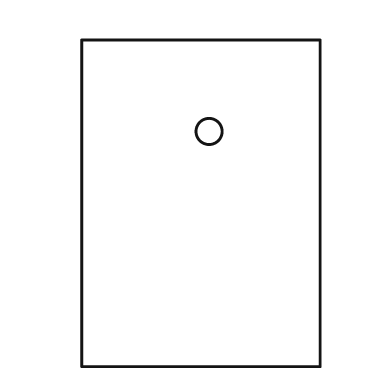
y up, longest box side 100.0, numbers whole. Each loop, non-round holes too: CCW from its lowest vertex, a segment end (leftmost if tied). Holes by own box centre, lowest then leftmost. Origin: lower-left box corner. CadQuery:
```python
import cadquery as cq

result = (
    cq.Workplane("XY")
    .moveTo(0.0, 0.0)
    .lineTo(73.0, 0.0)
    .lineTo(73.0, 100.0)
    .lineTo(0.0, 100.0)
    .close()
    .moveTo(39.0, 72.0)
    .circle(4.0)
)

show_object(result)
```